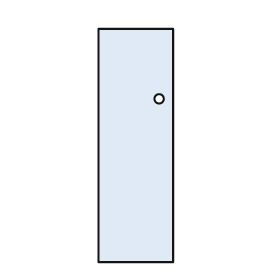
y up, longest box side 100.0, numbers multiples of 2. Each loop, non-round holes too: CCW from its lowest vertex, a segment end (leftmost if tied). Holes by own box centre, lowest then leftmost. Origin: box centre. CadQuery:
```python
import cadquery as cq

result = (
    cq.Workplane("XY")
    .moveTo(-16.0, -50.0)
    .lineTo(16.0, -50.0)
    .lineTo(16.0, 50.0)
    .lineTo(-16.0, 50.0)
    .close()
    .moveTo(10.0, 20.0)
    .circle(2.0)
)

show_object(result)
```